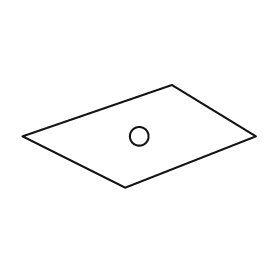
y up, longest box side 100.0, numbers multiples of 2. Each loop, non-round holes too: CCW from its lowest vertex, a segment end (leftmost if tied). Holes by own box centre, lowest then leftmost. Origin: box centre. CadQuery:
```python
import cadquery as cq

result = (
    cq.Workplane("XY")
    .moveTo(-6.0, -22.0)
    .lineTo(50.0, 0.0)
    .lineTo(14.0, 22.0)
    .lineTo(-50.0, 0.0)
    .close()
    .moveTo(0.0, 0.0)
    .circle(4.0)
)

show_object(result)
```